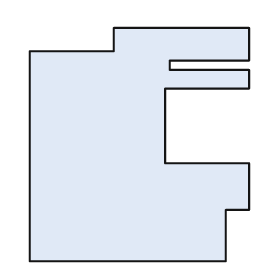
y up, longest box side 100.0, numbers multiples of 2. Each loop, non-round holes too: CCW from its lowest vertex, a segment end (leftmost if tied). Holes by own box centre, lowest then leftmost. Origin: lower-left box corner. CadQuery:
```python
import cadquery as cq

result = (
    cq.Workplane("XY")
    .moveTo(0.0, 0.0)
    .lineTo(84.0, 0.0)
    .lineTo(84.0, 22.0)
    .lineTo(94.0, 22.0)
    .lineTo(94.0, 42.0)
    .lineTo(58.0, 42.0)
    .lineTo(58.0, 74.0)
    .lineTo(94.0, 74.0)
    .lineTo(94.0, 82.0)
    .lineTo(60.0, 82.0)
    .lineTo(60.0, 86.0)
    .lineTo(94.0, 86.0)
    .lineTo(94.0, 100.0)
    .lineTo(36.0, 100.0)
    .lineTo(36.0, 90.0)
    .lineTo(0.0, 90.0)
    .close()
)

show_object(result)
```